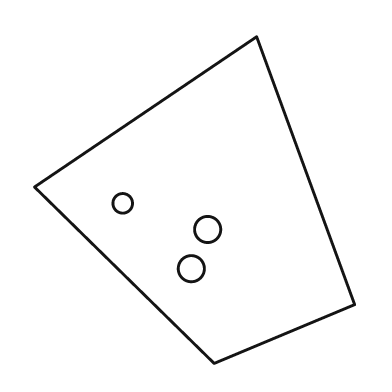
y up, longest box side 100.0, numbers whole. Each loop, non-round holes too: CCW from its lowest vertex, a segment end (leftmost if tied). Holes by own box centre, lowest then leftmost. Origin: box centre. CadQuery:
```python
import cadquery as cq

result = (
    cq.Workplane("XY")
    .moveTo(6.0, -50.0)
    .lineTo(49.0, -32.0)
    .lineTo(19.0, 50.0)
    .lineTo(-49.0, 4.0)
    .close()
    .moveTo(-1.0, -21.0)
    .circle(4.0)
    .moveTo(4.0, -9.0)
    .circle(4.0)
    .moveTo(-22.0, -1.0)
    .circle(3.0)
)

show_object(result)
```